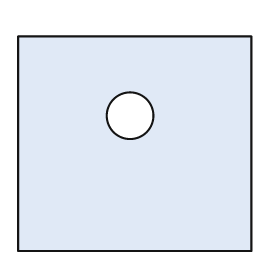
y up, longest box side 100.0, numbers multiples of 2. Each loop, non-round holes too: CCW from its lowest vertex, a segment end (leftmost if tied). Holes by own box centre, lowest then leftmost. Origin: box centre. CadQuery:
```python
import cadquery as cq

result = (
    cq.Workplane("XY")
    .moveTo(-50.0, -46.0)
    .lineTo(50.0, -46.0)
    .lineTo(50.0, 46.0)
    .lineTo(-50.0, 46.0)
    .close()
    .moveTo(-2.0, 12.0)
    .circle(10.0)
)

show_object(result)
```